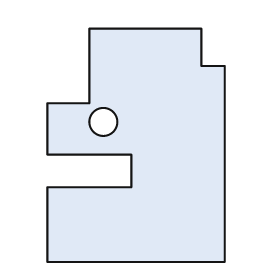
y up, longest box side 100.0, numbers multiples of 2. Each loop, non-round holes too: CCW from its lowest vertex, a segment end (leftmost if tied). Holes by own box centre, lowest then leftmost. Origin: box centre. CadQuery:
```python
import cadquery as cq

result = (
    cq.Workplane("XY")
    .moveTo(-38.0, -50.0)
    .lineTo(38.0, -50.0)
    .lineTo(38.0, 34.0)
    .lineTo(28.0, 34.0)
    .lineTo(28.0, 50.0)
    .lineTo(-20.0, 50.0)
    .lineTo(-20.0, 18.0)
    .lineTo(-38.0, 18.0)
    .lineTo(-38.0, -4.0)
    .lineTo(-2.0, -4.0)
    .lineTo(-2.0, -18.0)
    .lineTo(-38.0, -18.0)
    .close()
    .moveTo(-14.0, 10.0)
    .circle(6.0)
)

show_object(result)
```